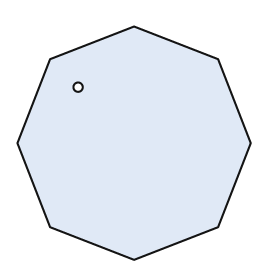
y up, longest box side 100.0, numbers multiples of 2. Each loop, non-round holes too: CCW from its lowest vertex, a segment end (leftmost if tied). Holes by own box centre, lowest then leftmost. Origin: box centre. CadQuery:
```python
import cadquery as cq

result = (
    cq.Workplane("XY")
    .moveTo(0.0, -50.0)
    .lineTo(36.0, -36.0)
    .lineTo(50.0, 0.0)
    .lineTo(36.0, 36.0)
    .lineTo(0.0, 50.0)
    .lineTo(-36.0, 36.0)
    .lineTo(-50.0, 0.0)
    .lineTo(-36.0, -36.0)
    .close()
    .moveTo(-24.0, 24.0)
    .circle(2.0)
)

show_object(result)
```